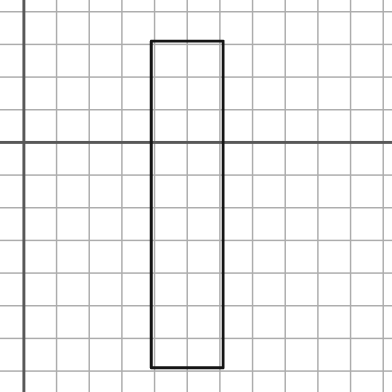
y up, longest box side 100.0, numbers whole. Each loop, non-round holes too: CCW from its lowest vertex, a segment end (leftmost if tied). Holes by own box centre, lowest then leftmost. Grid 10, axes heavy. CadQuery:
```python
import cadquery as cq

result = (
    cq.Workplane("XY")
    .moveTo(39.0, -69.0)
    .lineTo(61.0, -69.0)
    .lineTo(61.0, 31.0)
    .lineTo(39.0, 31.0)
    .close()
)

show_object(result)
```